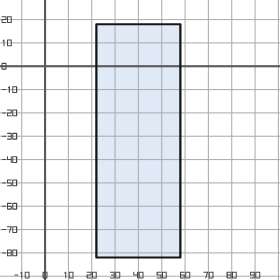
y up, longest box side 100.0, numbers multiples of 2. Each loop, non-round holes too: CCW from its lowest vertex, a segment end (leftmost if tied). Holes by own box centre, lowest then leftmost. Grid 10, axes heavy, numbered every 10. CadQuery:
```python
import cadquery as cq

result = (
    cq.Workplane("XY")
    .moveTo(22.0, -82.0)
    .lineTo(58.0, -82.0)
    .lineTo(58.0, 18.0)
    .lineTo(22.0, 18.0)
    .close()
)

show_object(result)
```